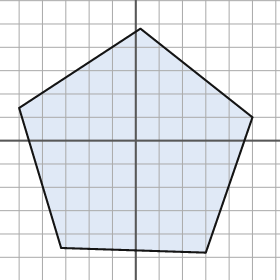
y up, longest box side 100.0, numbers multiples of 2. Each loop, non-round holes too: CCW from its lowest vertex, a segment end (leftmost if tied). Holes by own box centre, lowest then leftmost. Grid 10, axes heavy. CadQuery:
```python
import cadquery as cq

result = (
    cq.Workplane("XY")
    .moveTo(30.0, -48.0)
    .lineTo(50.0, 10.0)
    .lineTo(2.0, 48.0)
    .lineTo(-50.0, 14.0)
    .lineTo(-32.0, -46.0)
    .close()
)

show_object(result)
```